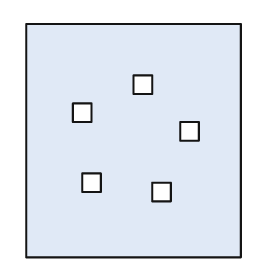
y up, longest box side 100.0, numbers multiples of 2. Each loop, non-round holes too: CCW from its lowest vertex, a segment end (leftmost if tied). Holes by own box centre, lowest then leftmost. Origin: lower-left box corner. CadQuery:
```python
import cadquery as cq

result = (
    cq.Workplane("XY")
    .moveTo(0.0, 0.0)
    .lineTo(92.0, 0.0)
    .lineTo(92.0, 100.0)
    .lineTo(0.0, 100.0)
    .close()
    .moveTo(54.0, 24.0)
    .lineTo(62.0, 24.0)
    .lineTo(62.0, 32.0)
    .lineTo(54.0, 32.0)
    .close()
    .moveTo(24.0, 28.0)
    .lineTo(32.0, 28.0)
    .lineTo(32.0, 36.0)
    .lineTo(24.0, 36.0)
    .close()
    .moveTo(66.0, 50.0)
    .lineTo(74.0, 50.0)
    .lineTo(74.0, 58.0)
    .lineTo(66.0, 58.0)
    .close()
    .moveTo(20.0, 58.0)
    .lineTo(28.0, 58.0)
    .lineTo(28.0, 66.0)
    .lineTo(20.0, 66.0)
    .close()
    .moveTo(46.0, 70.0)
    .lineTo(54.0, 70.0)
    .lineTo(54.0, 78.0)
    .lineTo(46.0, 78.0)
    .close()
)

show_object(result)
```